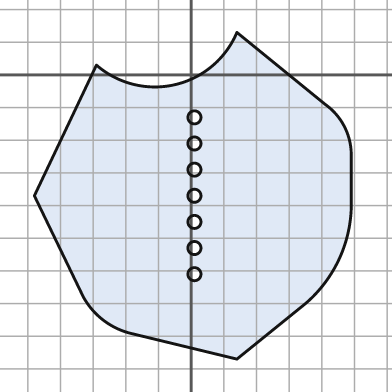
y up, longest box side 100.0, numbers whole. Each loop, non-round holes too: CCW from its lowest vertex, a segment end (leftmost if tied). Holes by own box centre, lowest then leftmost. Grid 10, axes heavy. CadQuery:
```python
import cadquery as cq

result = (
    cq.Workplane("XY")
    .moveTo(14.0, -87.0)
    .lineTo(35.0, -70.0)
    .threePointArc((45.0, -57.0), (49.0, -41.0))
    .lineTo(49.0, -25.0)
    .threePointArc((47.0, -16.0), (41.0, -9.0))
    .lineTo(14.0, 13.0)
    .threePointArc((-5.0, -3.0), (-29.0, 3.0))
    .lineTo(-48.0, -37.0)
    .lineTo(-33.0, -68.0)
    .threePointArc((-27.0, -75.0), (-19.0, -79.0))
    .close()
    .moveTo(1.0, -61.0)
    .circle(2.0)
    .moveTo(1.0, -53.0)
    .circle(2.0)
    .moveTo(1.0, -45.0)
    .circle(2.0)
    .moveTo(1.0, -37.0)
    .circle(2.0)
    .moveTo(1.0, -29.0)
    .circle(2.0)
    .moveTo(1.0, -21.0)
    .circle(2.0)
    .moveTo(1.0, -13.0)
    .circle(2.0)
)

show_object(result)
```